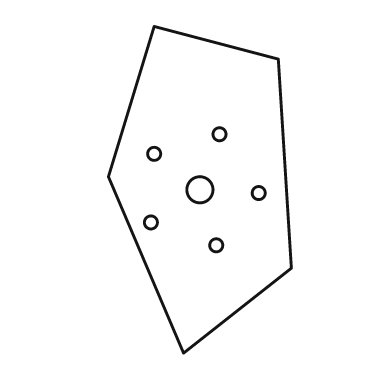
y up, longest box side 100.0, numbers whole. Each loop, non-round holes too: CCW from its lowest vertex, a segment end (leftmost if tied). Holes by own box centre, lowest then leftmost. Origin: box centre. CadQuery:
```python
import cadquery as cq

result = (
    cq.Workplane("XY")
    .moveTo(-5.0, -50.0)
    .lineTo(28.0, -24.0)
    .lineTo(24.0, 40.0)
    .lineTo(-14.0, 50.0)
    .lineTo(-28.0, 4.0)
    .close()
    .moveTo(5.0, -17.0)
    .circle(2.0)
    .moveTo(-15.0, -10.0)
    .circle(2.0)
    .moveTo(18.0, -1.0)
    .circle(2.0)
    .moveTo(0.0, 0.0)
    .circle(4.0)
    .moveTo(-14.0, 11.0)
    .circle(2.0)
    .moveTo(6.0, 17.0)
    .circle(2.0)
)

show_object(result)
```